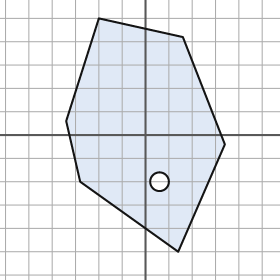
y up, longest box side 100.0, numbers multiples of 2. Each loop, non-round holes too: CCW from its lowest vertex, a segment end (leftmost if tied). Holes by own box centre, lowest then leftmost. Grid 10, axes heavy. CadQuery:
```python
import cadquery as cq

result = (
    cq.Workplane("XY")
    .moveTo(14.0, -50.0)
    .lineTo(34.0, -4.0)
    .lineTo(16.0, 42.0)
    .lineTo(-20.0, 50.0)
    .lineTo(-34.0, 6.0)
    .lineTo(-28.0, -20.0)
    .close()
    .moveTo(6.0, -20.0)
    .circle(4.0)
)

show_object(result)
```